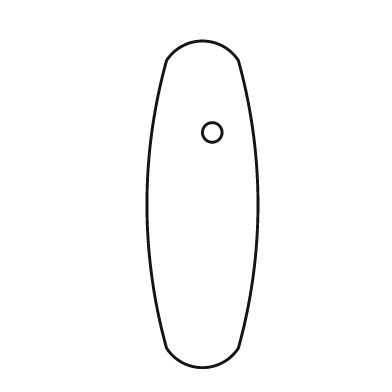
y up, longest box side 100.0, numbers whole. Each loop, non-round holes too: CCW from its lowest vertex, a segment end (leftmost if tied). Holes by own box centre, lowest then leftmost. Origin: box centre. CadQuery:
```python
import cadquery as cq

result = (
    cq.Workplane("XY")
    .moveTo(-11.0, -44.0)
    .threePointArc((0.0, -50.0), (11.0, -44.0))
    .threePointArc((17.0, 0.0), (11.0, 44.0))
    .threePointArc((0.0, 50.0), (-11.0, 44.0))
    .threePointArc((-17.0, 0.0), (-11.0, -44.0))
    .close()
    .moveTo(3.0, 22.0)
    .circle(3.0)
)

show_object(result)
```